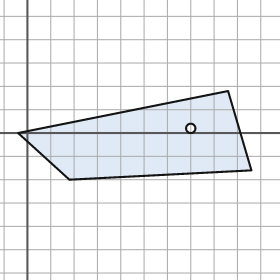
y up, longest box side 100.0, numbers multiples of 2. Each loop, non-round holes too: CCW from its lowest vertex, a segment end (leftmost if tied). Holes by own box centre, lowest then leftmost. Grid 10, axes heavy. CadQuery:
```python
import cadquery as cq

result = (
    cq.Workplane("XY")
    .moveTo(18.0, -20.0)
    .lineTo(96.0, -16.0)
    .lineTo(86.0, 18.0)
    .lineTo(-4.0, 0.0)
    .close()
    .moveTo(70.0, 2.0)
    .circle(2.0)
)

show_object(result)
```